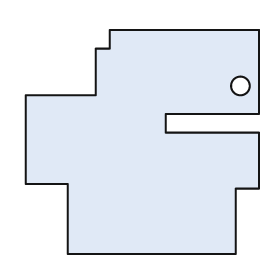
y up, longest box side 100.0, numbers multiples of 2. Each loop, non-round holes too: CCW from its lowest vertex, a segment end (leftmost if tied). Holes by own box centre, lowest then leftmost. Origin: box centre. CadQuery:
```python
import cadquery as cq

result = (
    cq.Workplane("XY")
    .moveTo(-32.0, -48.0)
    .lineTo(40.0, -48.0)
    .lineTo(40.0, -20.0)
    .lineTo(50.0, -20.0)
    .lineTo(50.0, 4.0)
    .lineTo(10.0, 4.0)
    .lineTo(10.0, 12.0)
    .lineTo(50.0, 12.0)
    .lineTo(50.0, 48.0)
    .lineTo(-14.0, 48.0)
    .lineTo(-14.0, 40.0)
    .lineTo(-20.0, 40.0)
    .lineTo(-20.0, 20.0)
    .lineTo(-50.0, 20.0)
    .lineTo(-50.0, -18.0)
    .lineTo(-32.0, -18.0)
    .close()
    .moveTo(42.0, 24.0)
    .circle(4.0)
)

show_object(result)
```